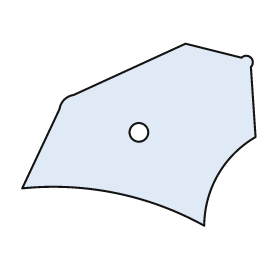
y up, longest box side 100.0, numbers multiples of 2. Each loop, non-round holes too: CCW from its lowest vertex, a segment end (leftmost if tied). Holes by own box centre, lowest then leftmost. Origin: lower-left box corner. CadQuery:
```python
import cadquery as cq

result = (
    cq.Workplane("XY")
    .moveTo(78.0, 0.0)
    .threePointArc((84.0, 22.0), (100.0, 38.0))
    .lineTo(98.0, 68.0)
    .threePointArc((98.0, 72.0), (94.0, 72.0))
    .lineTo(70.0, 78.0)
    .lineTo(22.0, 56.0)
    .threePointArc((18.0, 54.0), (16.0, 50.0))
    .lineTo(0.0, 16.0)
    .threePointArc((40.0, 14.0), (78.0, 0.0))
    .close()
    .moveTo(50.0, 40.0)
    .circle(4.0)
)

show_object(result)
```